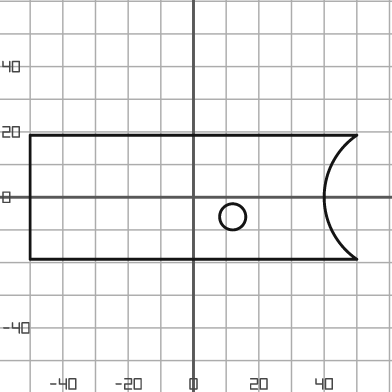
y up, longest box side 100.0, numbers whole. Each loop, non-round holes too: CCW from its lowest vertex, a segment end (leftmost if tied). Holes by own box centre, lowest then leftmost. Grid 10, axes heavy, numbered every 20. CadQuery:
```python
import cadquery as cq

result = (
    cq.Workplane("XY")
    .moveTo(-50.0, -19.0)
    .lineTo(50.0, -19.0)
    .threePointArc((40.0, 0.0), (50.0, 19.0))
    .lineTo(-50.0, 19.0)
    .close()
    .moveTo(12.0, -6.0)
    .circle(4.0)
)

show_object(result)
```